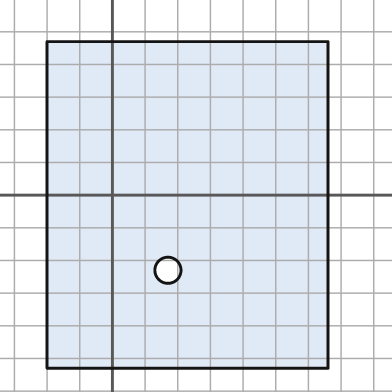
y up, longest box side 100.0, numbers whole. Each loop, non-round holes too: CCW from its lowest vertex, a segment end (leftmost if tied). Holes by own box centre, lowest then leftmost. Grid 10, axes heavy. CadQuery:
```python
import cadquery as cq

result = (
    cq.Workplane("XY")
    .moveTo(-20.0, -53.0)
    .lineTo(66.0, -53.0)
    .lineTo(66.0, 47.0)
    .lineTo(-20.0, 47.0)
    .close()
    .moveTo(17.0, -23.0)
    .circle(4.0)
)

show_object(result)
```